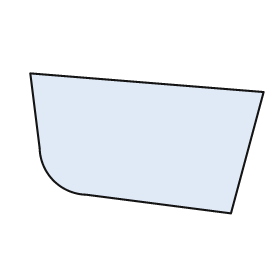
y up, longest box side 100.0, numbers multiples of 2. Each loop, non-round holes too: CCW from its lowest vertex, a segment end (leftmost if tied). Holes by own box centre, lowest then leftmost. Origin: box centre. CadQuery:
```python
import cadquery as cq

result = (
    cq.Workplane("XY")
    .moveTo(36.0, -30.0)
    .lineTo(50.0, 22.0)
    .lineTo(-50.0, 30.0)
    .lineTo(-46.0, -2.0)
    .threePointArc((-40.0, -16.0), (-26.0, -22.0))
    .close()
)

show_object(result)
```